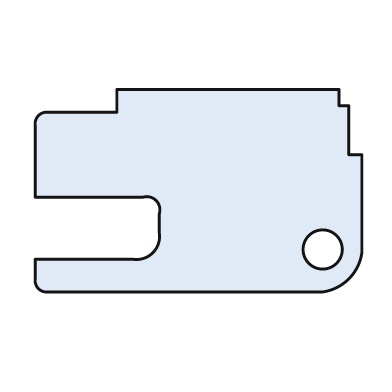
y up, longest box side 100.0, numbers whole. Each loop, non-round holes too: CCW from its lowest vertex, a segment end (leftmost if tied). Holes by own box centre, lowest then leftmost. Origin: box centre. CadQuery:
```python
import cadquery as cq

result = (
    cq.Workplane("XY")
    .moveTo(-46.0, -31.0)
    .lineTo(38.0, -31.0)
    .threePointArc((46.0, -27.0), (50.0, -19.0))
    .lineTo(50.0, 11.0)
    .lineTo(46.0, 11.0)
    .lineTo(46.0, 26.0)
    .lineTo(43.0, 26.0)
    .lineTo(43.0, 31.0)
    .lineTo(-25.0, 31.0)
    .lineTo(-25.0, 24.0)
    .lineTo(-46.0, 24.0)
    .threePointArc((-49.0, 23.0), (-50.0, 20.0))
    .lineTo(-50.0, -2.0)
    .lineTo(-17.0, -2.0)
    .threePointArc((-13.0, -3.0), (-12.0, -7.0))
    .lineTo(-12.0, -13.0)
    .threePointArc((-14.0, -19.0), (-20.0, -21.0))
    .lineTo(-50.0, -21.0)
    .lineTo(-50.0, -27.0)
    .threePointArc((-49.0, -30.0), (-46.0, -31.0))
    .close()
    .moveTo(38.0, -18.0)
    .circle(6.0)
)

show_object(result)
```